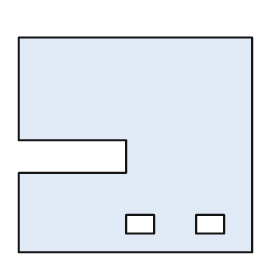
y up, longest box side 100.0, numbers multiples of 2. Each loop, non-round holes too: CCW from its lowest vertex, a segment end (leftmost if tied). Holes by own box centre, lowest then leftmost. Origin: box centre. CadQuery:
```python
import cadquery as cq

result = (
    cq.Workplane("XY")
    .moveTo(-50.0, -46.0)
    .lineTo(50.0, -46.0)
    .lineTo(50.0, 46.0)
    .lineTo(-50.0, 46.0)
    .lineTo(-50.0, 2.0)
    .lineTo(-4.0, 2.0)
    .lineTo(-4.0, -12.0)
    .lineTo(-50.0, -12.0)
    .close()
    .moveTo(-4.0, -38.0)
    .lineTo(8.0, -38.0)
    .lineTo(8.0, -30.0)
    .lineTo(-4.0, -30.0)
    .close()
    .moveTo(26.0, -38.0)
    .lineTo(38.0, -38.0)
    .lineTo(38.0, -30.0)
    .lineTo(26.0, -30.0)
    .close()
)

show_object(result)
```